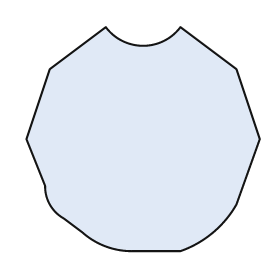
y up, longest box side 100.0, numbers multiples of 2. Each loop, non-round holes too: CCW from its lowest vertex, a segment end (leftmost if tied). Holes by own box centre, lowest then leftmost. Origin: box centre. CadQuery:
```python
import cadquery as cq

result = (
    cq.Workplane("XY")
    .moveTo(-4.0, -48.0)
    .lineTo(16.0, -48.0)
    .threePointArc((30.0, -40.0), (40.0, -28.0))
    .lineTo(50.0, 0.0)
    .lineTo(40.0, 30.0)
    .lineTo(16.0, 48.0)
    .threePointArc((0.0, 40.0), (-16.0, 48.0))
    .lineTo(-40.0, 30.0)
    .lineTo(-50.0, 0.0)
    .lineTo(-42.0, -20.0)
    .threePointArc((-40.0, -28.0), (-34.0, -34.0))
    .lineTo(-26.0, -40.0)
    .threePointArc((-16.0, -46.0), (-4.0, -48.0))
    .close()
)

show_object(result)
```